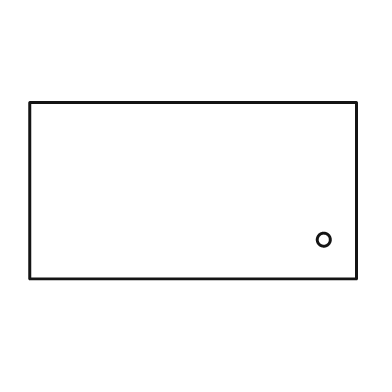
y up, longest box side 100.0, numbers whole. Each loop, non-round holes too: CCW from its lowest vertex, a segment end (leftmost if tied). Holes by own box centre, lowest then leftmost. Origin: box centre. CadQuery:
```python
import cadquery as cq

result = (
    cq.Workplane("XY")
    .moveTo(-50.0, -27.0)
    .lineTo(50.0, -27.0)
    .lineTo(50.0, 27.0)
    .lineTo(-50.0, 27.0)
    .close()
    .moveTo(40.0, -15.0)
    .circle(2.0)
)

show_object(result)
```